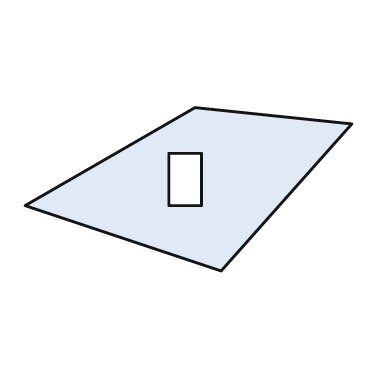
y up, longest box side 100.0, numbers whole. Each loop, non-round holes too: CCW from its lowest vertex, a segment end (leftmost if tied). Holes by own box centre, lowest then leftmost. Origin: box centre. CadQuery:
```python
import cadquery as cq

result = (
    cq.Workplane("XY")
    .moveTo(10.0, -25.0)
    .lineTo(50.0, 20.0)
    .lineTo(2.0, 25.0)
    .lineTo(-50.0, -5.0)
    .close()
    .moveTo(-6.0, -5.0)
    .lineTo(4.0, -5.0)
    .lineTo(4.0, 11.0)
    .lineTo(-6.0, 11.0)
    .close()
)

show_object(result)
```